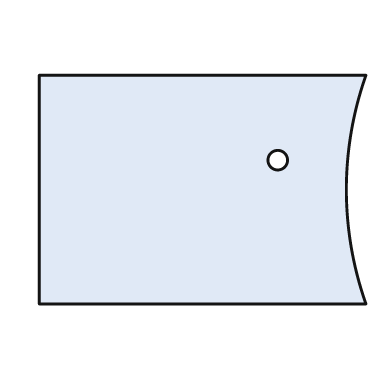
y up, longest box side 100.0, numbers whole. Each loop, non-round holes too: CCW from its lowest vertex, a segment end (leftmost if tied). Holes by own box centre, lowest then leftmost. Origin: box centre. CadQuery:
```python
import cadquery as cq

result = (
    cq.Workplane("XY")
    .moveTo(-50.0, -35.0)
    .lineTo(50.0, -35.0)
    .threePointArc((44.0, 0.0), (50.0, 35.0))
    .lineTo(-50.0, 35.0)
    .close()
    .moveTo(23.0, 9.0)
    .circle(3.0)
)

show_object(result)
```